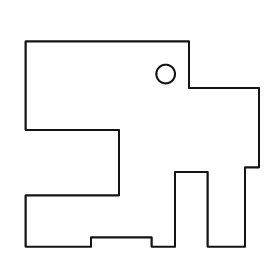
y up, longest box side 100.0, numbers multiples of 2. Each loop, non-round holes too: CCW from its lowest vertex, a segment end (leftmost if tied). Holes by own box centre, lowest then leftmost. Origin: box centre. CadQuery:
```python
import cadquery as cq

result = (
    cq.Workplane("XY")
    .moveTo(-50.0, -44.0)
    .lineTo(-22.0, -44.0)
    .lineTo(-22.0, -40.0)
    .lineTo(4.0, -40.0)
    .lineTo(4.0, -44.0)
    .lineTo(14.0, -44.0)
    .lineTo(14.0, -12.0)
    .lineTo(28.0, -12.0)
    .lineTo(28.0, -44.0)
    .lineTo(44.0, -44.0)
    .lineTo(44.0, -10.0)
    .lineTo(50.0, -10.0)
    .lineTo(50.0, 24.0)
    .lineTo(20.0, 24.0)
    .lineTo(20.0, 44.0)
    .lineTo(-50.0, 44.0)
    .lineTo(-50.0, 6.0)
    .lineTo(-10.0, 6.0)
    .lineTo(-10.0, -22.0)
    .lineTo(-50.0, -22.0)
    .close()
    .moveTo(10.0, 30.0)
    .circle(4.0)
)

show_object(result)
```